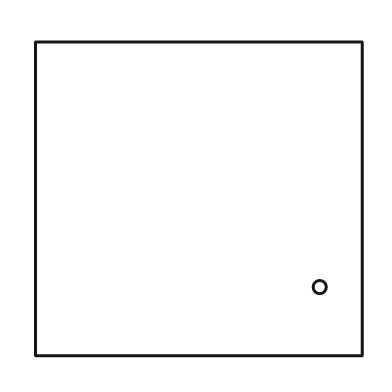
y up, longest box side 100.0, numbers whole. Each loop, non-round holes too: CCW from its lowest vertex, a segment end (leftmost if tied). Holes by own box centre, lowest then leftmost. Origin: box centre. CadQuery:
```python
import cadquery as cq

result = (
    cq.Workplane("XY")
    .moveTo(-50.0, -48.0)
    .lineTo(50.0, -48.0)
    .lineTo(50.0, 48.0)
    .lineTo(-50.0, 48.0)
    .close()
    .moveTo(37.0, -27.0)
    .circle(2.0)
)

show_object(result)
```